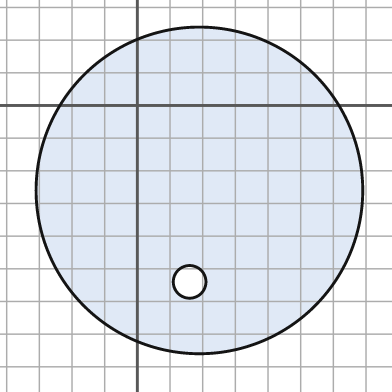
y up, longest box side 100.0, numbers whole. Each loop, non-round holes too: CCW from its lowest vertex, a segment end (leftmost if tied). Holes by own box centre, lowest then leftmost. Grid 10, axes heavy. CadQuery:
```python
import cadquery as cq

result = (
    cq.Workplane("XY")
    .moveTo(19.0, -26.0)
    .circle(50.0)
    .moveTo(16.0, -54.0)
    .circle(5.0)
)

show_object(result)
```